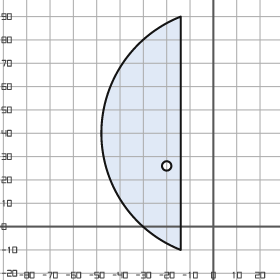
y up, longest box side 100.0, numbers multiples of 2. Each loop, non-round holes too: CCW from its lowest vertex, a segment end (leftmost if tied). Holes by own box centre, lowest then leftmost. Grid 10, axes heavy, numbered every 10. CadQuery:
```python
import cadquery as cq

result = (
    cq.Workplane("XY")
    .moveTo(-14.0, -10.0)
    .lineTo(-14.0, 90.0)
    .threePointArc((-48.0, 40.0), (-14.0, -10.0))
    .close()
    .moveTo(-20.0, 26.0)
    .circle(2.0)
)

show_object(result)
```